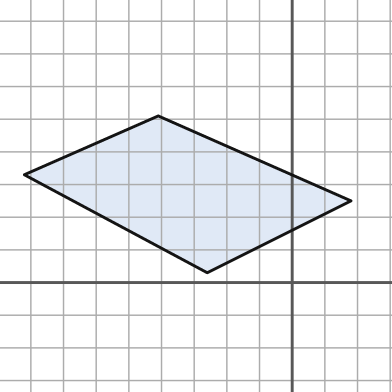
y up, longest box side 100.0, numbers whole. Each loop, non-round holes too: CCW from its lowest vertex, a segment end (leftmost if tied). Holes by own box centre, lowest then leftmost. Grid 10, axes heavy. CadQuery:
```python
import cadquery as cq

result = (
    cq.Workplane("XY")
    .moveTo(-26.0, 3.0)
    .lineTo(18.0, 25.0)
    .lineTo(-41.0, 51.0)
    .lineTo(-82.0, 33.0)
    .close()
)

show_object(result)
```